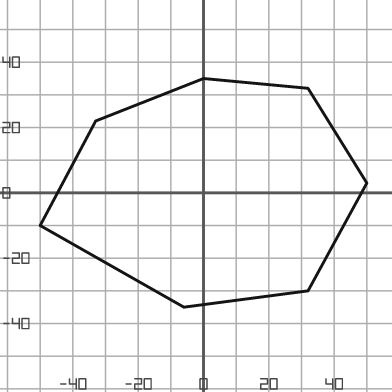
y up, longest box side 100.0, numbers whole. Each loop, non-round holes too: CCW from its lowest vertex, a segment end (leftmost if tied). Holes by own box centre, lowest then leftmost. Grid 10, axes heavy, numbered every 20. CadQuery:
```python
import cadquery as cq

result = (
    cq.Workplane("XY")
    .moveTo(-6.0, -35.0)
    .lineTo(32.0, -30.0)
    .lineTo(50.0, 3.0)
    .lineTo(32.0, 32.0)
    .lineTo(0.0, 35.0)
    .lineTo(-33.0, 22.0)
    .lineTo(-50.0, -10.0)
    .close()
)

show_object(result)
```